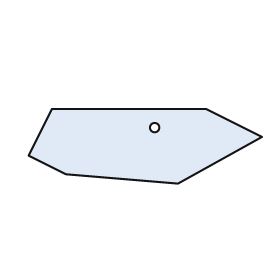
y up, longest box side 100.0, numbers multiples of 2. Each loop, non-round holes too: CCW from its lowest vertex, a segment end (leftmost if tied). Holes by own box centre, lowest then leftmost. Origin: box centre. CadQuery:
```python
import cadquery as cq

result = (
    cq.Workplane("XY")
    .moveTo(14.0, -16.0)
    .lineTo(50.0, 4.0)
    .lineTo(26.0, 16.0)
    .lineTo(-40.0, 16.0)
    .lineTo(-50.0, -4.0)
    .lineTo(-34.0, -12.0)
    .close()
    .moveTo(4.0, 8.0)
    .circle(2.0)
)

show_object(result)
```